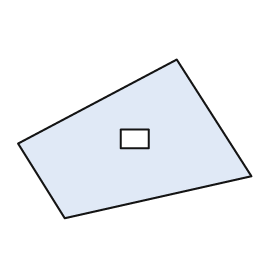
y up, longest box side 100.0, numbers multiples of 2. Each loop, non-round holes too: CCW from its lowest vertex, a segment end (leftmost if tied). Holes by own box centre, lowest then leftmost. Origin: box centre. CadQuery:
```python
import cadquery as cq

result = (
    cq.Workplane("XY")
    .moveTo(-30.0, -34.0)
    .lineTo(50.0, -16.0)
    .lineTo(18.0, 34.0)
    .lineTo(-50.0, -2.0)
    .close()
    .moveTo(-6.0, -4.0)
    .lineTo(6.0, -4.0)
    .lineTo(6.0, 4.0)
    .lineTo(-6.0, 4.0)
    .close()
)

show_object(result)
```